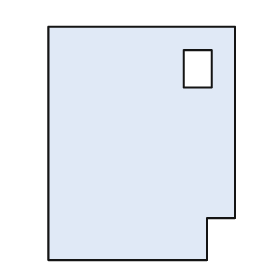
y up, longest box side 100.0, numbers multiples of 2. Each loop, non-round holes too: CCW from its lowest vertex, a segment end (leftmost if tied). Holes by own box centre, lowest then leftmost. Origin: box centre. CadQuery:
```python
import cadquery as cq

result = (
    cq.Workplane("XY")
    .moveTo(-40.0, -50.0)
    .lineTo(28.0, -50.0)
    .lineTo(28.0, -32.0)
    .lineTo(40.0, -32.0)
    .lineTo(40.0, 50.0)
    .lineTo(-40.0, 50.0)
    .close()
    .moveTo(18.0, 24.0)
    .lineTo(30.0, 24.0)
    .lineTo(30.0, 40.0)
    .lineTo(18.0, 40.0)
    .close()
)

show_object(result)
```